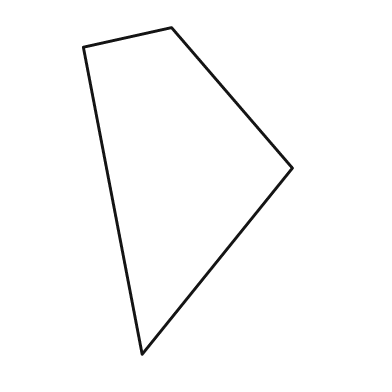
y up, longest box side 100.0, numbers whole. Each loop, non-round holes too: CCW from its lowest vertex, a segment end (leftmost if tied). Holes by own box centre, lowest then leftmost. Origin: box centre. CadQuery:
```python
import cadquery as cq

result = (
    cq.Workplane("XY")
    .moveTo(-14.0, -50.0)
    .lineTo(32.0, 7.0)
    .lineTo(-5.0, 50.0)
    .lineTo(-32.0, 44.0)
    .close()
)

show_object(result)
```